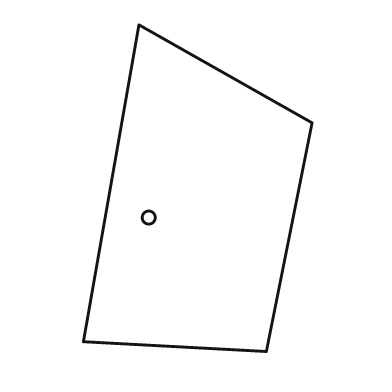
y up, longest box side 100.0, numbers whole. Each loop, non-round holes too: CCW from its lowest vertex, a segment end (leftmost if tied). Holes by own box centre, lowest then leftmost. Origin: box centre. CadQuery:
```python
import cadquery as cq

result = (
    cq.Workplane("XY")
    .moveTo(21.0, -50.0)
    .lineTo(35.0, 20.0)
    .lineTo(-18.0, 50.0)
    .lineTo(-35.0, -47.0)
    .close()
    .moveTo(-15.0, -9.0)
    .circle(2.0)
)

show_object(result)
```